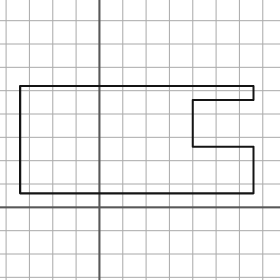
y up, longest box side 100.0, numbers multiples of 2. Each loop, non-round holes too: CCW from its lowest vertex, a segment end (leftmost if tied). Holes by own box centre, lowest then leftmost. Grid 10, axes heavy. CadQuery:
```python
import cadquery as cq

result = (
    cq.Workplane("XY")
    .moveTo(-34.0, 6.0)
    .lineTo(66.0, 6.0)
    .lineTo(66.0, 26.0)
    .lineTo(40.0, 26.0)
    .lineTo(40.0, 46.0)
    .lineTo(66.0, 46.0)
    .lineTo(66.0, 52.0)
    .lineTo(-34.0, 52.0)
    .close()
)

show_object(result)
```